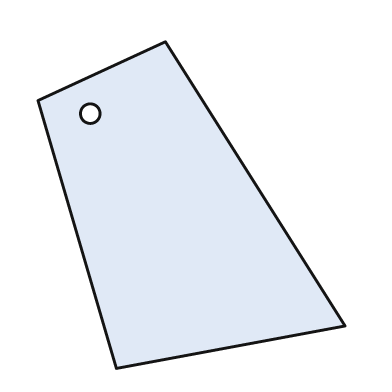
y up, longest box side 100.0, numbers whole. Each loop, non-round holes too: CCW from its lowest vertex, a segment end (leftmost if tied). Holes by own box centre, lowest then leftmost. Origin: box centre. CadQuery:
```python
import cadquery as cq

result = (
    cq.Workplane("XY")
    .moveTo(-23.0, -50.0)
    .lineTo(47.0, -37.0)
    .lineTo(-8.0, 50.0)
    .lineTo(-47.0, 32.0)
    .close()
    .moveTo(-31.0, 28.0)
    .circle(3.0)
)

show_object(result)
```